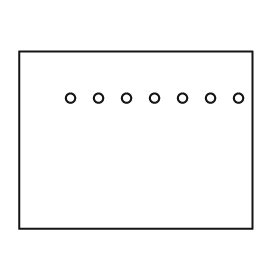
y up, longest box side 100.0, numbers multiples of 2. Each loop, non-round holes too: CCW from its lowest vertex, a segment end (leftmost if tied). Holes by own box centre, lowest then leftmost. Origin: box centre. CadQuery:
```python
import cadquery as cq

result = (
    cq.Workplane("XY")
    .moveTo(-50.0, -38.0)
    .lineTo(50.0, -38.0)
    .lineTo(50.0, 38.0)
    .lineTo(-50.0, 38.0)
    .close()
    .moveTo(-28.0, 18.0)
    .circle(2.0)
    .moveTo(-16.0, 18.0)
    .circle(2.0)
    .moveTo(-4.0, 18.0)
    .circle(2.0)
    .moveTo(8.0, 18.0)
    .circle(2.0)
    .moveTo(20.0, 18.0)
    .circle(2.0)
    .moveTo(32.0, 18.0)
    .circle(2.0)
    .moveTo(44.0, 18.0)
    .circle(2.0)
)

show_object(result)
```